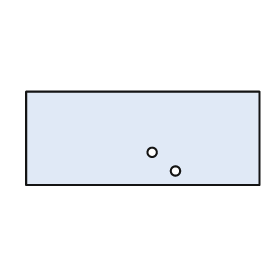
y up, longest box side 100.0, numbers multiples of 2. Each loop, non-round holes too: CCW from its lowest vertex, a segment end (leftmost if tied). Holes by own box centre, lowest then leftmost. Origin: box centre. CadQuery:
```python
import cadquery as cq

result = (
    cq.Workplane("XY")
    .moveTo(-50.0, -20.0)
    .lineTo(50.0, -20.0)
    .lineTo(50.0, 20.0)
    .lineTo(-50.0, 20.0)
    .close()
    .moveTo(14.0, -14.0)
    .circle(2.0)
    .moveTo(4.0, -6.0)
    .circle(2.0)
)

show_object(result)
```